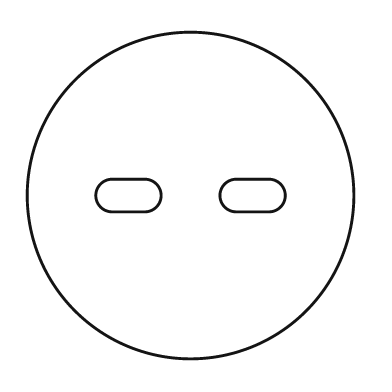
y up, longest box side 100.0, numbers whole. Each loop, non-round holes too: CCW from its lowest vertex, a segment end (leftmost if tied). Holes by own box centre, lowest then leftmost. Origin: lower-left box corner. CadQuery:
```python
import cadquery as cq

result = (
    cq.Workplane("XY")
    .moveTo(50.0, 50.0)
    .circle(50.0)
    .moveTo(26.0, 45.0)
    .lineTo(36.0, 45.0)
    .threePointArc((41.0, 50.0), (36.0, 55.0))
    .lineTo(26.0, 55.0)
    .threePointArc((21.0, 50.0), (26.0, 45.0))
    .close()
    .moveTo(64.0, 45.0)
    .lineTo(74.0, 45.0)
    .threePointArc((79.0, 50.0), (74.0, 55.0))
    .lineTo(64.0, 55.0)
    .threePointArc((59.0, 50.0), (64.0, 45.0))
    .close()
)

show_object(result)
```